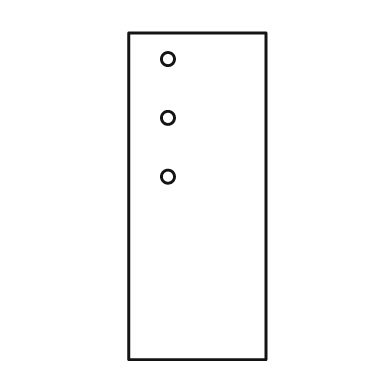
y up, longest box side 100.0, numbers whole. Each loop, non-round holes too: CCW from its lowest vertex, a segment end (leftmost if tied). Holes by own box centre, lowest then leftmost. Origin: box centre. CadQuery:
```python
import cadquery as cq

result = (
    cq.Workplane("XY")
    .moveTo(-21.0, -50.0)
    .lineTo(21.0, -50.0)
    .lineTo(21.0, 50.0)
    .lineTo(-21.0, 50.0)
    .close()
    .moveTo(-9.0, 6.0)
    .circle(2.0)
    .moveTo(-9.0, 24.0)
    .circle(2.0)
    .moveTo(-9.0, 42.0)
    .circle(2.0)
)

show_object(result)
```